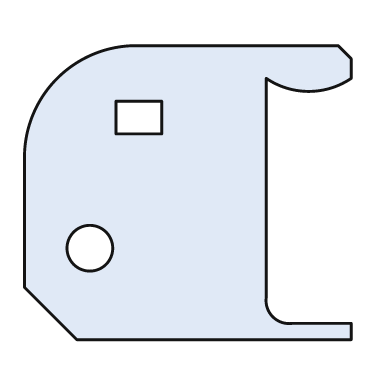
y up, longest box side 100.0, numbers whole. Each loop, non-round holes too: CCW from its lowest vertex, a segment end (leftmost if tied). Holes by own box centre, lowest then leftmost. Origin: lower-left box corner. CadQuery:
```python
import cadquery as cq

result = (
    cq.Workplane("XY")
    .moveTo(16.0, 0.0)
    .lineTo(100.0, 0.0)
    .lineTo(100.0, 5.0)
    .lineTo(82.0, 5.0)
    .threePointArc((76.0, 7.0), (74.0, 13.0))
    .lineTo(74.0, 80.0)
    .threePointArc((87.0, 76.0), (100.0, 80.0))
    .lineTo(100.0, 86.0)
    .lineTo(96.0, 90.0)
    .lineTo(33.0, 90.0)
    .threePointArc((10.0, 80.0), (0.0, 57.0))
    .lineTo(0.0, 16.0)
    .close()
    .moveTo(20.0, 28.0)
    .circle(7.0)
    .moveTo(28.0, 63.0)
    .lineTo(42.0, 63.0)
    .lineTo(42.0, 73.0)
    .lineTo(28.0, 73.0)
    .close()
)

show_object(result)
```